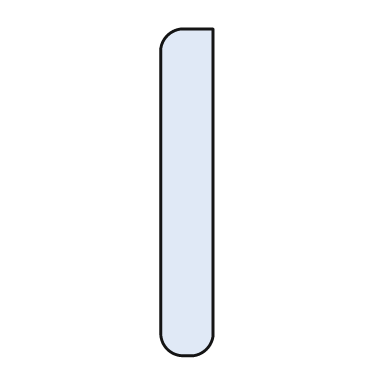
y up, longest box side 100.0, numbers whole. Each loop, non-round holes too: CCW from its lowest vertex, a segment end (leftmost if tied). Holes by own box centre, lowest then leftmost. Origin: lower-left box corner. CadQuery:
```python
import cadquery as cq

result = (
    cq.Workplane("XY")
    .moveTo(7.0, 0.0)
    .lineTo(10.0, 0.0)
    .threePointArc((14.0, 2.0), (16.0, 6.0))
    .lineTo(16.0, 100.0)
    .lineTo(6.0, 100.0)
    .threePointArc((2.0, 98.0), (0.0, 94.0))
    .lineTo(0.0, 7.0)
    .threePointArc((2.0, 2.0), (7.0, 0.0))
    .close()
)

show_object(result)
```